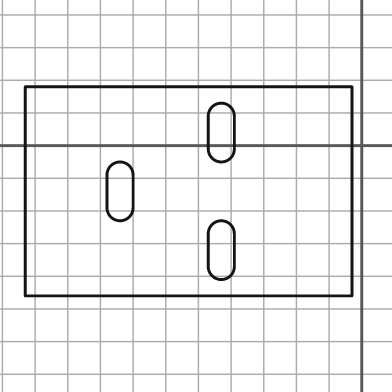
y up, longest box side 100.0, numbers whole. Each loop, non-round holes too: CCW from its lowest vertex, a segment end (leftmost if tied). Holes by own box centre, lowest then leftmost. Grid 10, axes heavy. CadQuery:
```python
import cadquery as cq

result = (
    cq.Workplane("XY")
    .moveTo(-103.0, -46.0)
    .lineTo(-3.0, -46.0)
    .lineTo(-3.0, 18.0)
    .lineTo(-103.0, 18.0)
    .close()
    .moveTo(-47.0, -37.0)
    .threePointArc((-43.0, -41.0), (-39.0, -37.0))
    .lineTo(-39.0, -27.0)
    .threePointArc((-43.0, -23.0), (-47.0, -27.0))
    .close()
    .moveTo(-78.0, -19.0)
    .threePointArc((-74.0, -23.0), (-70.0, -19.0))
    .lineTo(-70.0, -9.0)
    .threePointArc((-74.0, -5.0), (-78.0, -9.0))
    .close()
    .moveTo(-47.0, -1.0)
    .threePointArc((-43.0, -5.0), (-39.0, -1.0))
    .lineTo(-39.0, 9.0)
    .threePointArc((-43.0, 13.0), (-47.0, 9.0))
    .close()
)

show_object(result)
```